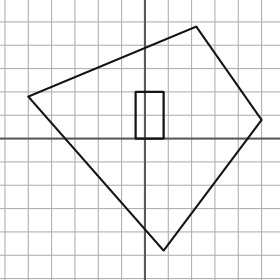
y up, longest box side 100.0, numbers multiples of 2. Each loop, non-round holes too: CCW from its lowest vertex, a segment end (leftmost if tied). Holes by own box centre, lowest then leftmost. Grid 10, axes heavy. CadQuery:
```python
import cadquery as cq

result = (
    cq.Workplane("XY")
    .moveTo(8.0, -48.0)
    .lineTo(50.0, 8.0)
    .lineTo(22.0, 48.0)
    .lineTo(-50.0, 18.0)
    .close()
    .moveTo(-4.0, 0.0)
    .lineTo(8.0, 0.0)
    .lineTo(8.0, 20.0)
    .lineTo(-4.0, 20.0)
    .close()
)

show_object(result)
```